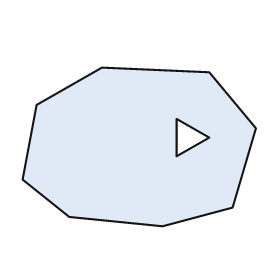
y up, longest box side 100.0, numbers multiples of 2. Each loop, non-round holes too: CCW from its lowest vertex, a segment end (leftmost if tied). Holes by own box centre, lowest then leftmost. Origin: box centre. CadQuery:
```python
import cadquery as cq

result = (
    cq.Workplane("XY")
    .moveTo(10.0, -34.0)
    .lineTo(40.0, -26.0)
    .lineTo(50.0, 8.0)
    .lineTo(30.0, 32.0)
    .lineTo(-16.0, 34.0)
    .lineTo(-44.0, 18.0)
    .lineTo(-50.0, -14.0)
    .lineTo(-30.0, -30.0)
    .close()
    .moveTo(16.0, -4.0)
    .lineTo(30.0, 4.0)
    .lineTo(16.0, 12.0)
    .close()
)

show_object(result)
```